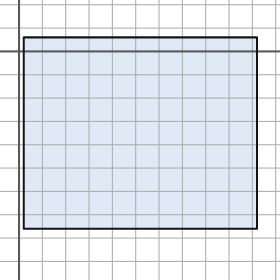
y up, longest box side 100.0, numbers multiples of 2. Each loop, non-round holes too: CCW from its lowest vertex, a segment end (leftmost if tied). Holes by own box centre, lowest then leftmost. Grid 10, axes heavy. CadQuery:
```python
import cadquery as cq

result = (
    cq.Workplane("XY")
    .moveTo(2.0, -76.0)
    .lineTo(102.0, -76.0)
    .lineTo(102.0, 6.0)
    .lineTo(2.0, 6.0)
    .close()
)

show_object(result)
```